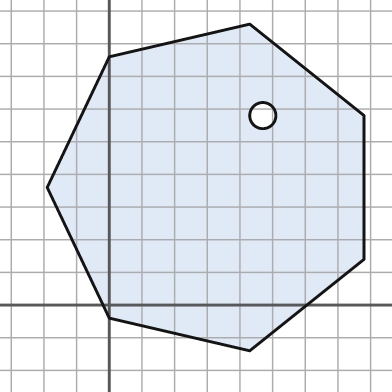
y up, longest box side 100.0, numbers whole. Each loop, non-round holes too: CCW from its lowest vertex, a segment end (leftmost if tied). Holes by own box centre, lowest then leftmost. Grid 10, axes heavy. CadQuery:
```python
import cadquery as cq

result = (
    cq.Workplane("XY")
    .moveTo(43.0, -14.0)
    .lineTo(78.0, 14.0)
    .lineTo(78.0, 58.0)
    .lineTo(43.0, 86.0)
    .lineTo(0.0, 76.0)
    .lineTo(-19.0, 36.0)
    .lineTo(0.0, -4.0)
    .close()
    .moveTo(47.0, 58.0)
    .circle(4.0)
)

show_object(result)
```